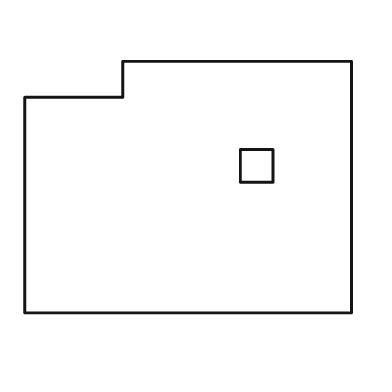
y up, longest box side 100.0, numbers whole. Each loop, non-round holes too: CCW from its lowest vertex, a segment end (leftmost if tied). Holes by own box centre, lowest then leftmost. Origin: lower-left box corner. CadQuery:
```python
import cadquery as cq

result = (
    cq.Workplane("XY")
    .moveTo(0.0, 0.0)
    .lineTo(100.0, 0.0)
    .lineTo(100.0, 77.0)
    .lineTo(30.0, 77.0)
    .lineTo(30.0, 66.0)
    .lineTo(0.0, 66.0)
    .close()
    .moveTo(66.0, 40.0)
    .lineTo(76.0, 40.0)
    .lineTo(76.0, 50.0)
    .lineTo(66.0, 50.0)
    .close()
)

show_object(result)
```